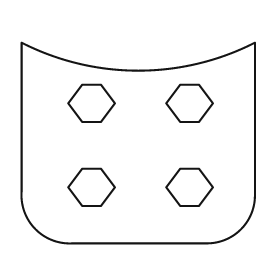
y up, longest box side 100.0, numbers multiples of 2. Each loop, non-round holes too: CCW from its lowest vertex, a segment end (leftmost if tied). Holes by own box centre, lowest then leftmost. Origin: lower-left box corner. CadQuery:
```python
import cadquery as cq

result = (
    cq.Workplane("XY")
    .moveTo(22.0, 0.0)
    .lineTo(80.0, 0.0)
    .threePointArc((94.0, 6.0), (100.0, 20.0))
    .lineTo(100.0, 86.0)
    .threePointArc((50.0, 74.0), (0.0, 86.0))
    .lineTo(0.0, 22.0)
    .threePointArc((6.0, 6.0), (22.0, 0.0))
    .close()
    .moveTo(26.0, 16.0)
    .lineTo(34.0, 16.0)
    .lineTo(40.0, 24.0)
    .lineTo(34.0, 32.0)
    .lineTo(26.0, 32.0)
    .lineTo(20.0, 24.0)
    .close()
    .moveTo(68.0, 16.0)
    .lineTo(76.0, 16.0)
    .lineTo(82.0, 24.0)
    .lineTo(76.0, 32.0)
    .lineTo(68.0, 32.0)
    .lineTo(62.0, 24.0)
    .close()
    .moveTo(26.0, 52.0)
    .lineTo(34.0, 52.0)
    .lineTo(40.0, 60.0)
    .lineTo(34.0, 68.0)
    .lineTo(26.0, 68.0)
    .lineTo(20.0, 60.0)
    .close()
    .moveTo(68.0, 52.0)
    .lineTo(76.0, 52.0)
    .lineTo(82.0, 60.0)
    .lineTo(76.0, 68.0)
    .lineTo(68.0, 68.0)
    .lineTo(62.0, 60.0)
    .close()
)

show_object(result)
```